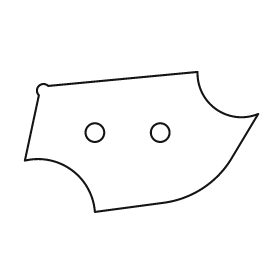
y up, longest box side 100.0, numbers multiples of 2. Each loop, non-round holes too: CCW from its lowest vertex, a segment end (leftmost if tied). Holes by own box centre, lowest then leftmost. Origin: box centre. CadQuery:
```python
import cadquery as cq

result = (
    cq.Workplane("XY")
    .moveTo(-20.0, -30.0)
    .lineTo(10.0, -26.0)
    .threePointArc((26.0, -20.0), (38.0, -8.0))
    .lineTo(50.0, 12.0)
    .threePointArc((32.0, 14.0), (24.0, 30.0))
    .lineTo(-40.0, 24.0)
    .threePointArc((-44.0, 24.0), (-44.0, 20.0))
    .lineTo(-50.0, -8.0)
    .threePointArc((-30.0, -12.0), (-20.0, -30.0))
    .close()
    .moveTo(-20.0, 4.0)
    .circle(4.0)
    .moveTo(8.0, 4.0)
    .circle(4.0)
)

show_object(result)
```